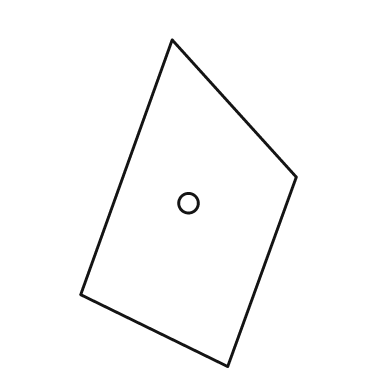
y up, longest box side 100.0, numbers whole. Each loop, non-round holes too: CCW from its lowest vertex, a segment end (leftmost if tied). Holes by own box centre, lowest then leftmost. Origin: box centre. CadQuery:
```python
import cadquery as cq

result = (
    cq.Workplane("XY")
    .moveTo(12.0, -50.0)
    .lineTo(33.0, 8.0)
    .lineTo(-5.0, 50.0)
    .lineTo(-33.0, -28.0)
    .close()
    .moveTo(0.0, 0.0)
    .circle(3.0)
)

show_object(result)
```